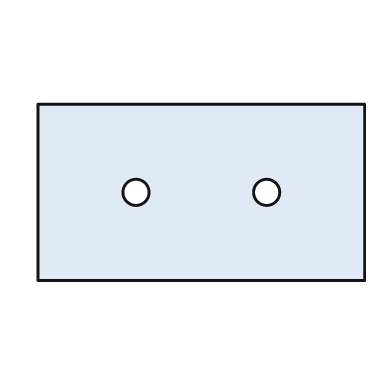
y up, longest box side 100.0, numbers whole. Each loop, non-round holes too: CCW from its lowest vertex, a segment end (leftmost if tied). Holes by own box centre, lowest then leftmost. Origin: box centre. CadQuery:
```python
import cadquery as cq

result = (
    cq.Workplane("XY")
    .moveTo(-50.0, -27.0)
    .lineTo(50.0, -27.0)
    .lineTo(50.0, 27.0)
    .lineTo(-50.0, 27.0)
    .close()
    .moveTo(-20.0, 0.0)
    .circle(4.0)
    .moveTo(20.0, 0.0)
    .circle(4.0)
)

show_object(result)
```